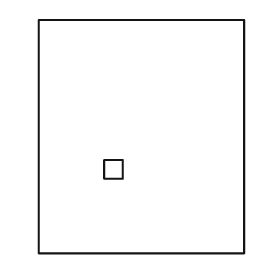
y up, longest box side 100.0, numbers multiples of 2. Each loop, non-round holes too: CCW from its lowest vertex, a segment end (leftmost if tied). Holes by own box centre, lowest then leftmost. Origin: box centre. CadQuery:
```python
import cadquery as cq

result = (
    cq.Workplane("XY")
    .moveTo(-44.0, -50.0)
    .lineTo(44.0, -50.0)
    .lineTo(44.0, 50.0)
    .lineTo(-44.0, 50.0)
    .close()
    .moveTo(-16.0, -18.0)
    .lineTo(-8.0, -18.0)
    .lineTo(-8.0, -10.0)
    .lineTo(-16.0, -10.0)
    .close()
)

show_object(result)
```